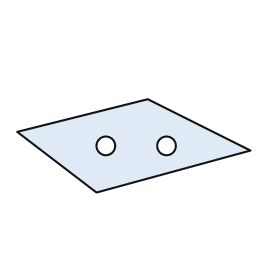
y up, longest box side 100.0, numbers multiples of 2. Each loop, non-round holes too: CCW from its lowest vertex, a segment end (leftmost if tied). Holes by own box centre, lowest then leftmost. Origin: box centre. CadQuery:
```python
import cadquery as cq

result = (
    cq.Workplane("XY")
    .moveTo(-16.0, -20.0)
    .lineTo(50.0, -2.0)
    .lineTo(6.0, 20.0)
    .lineTo(-50.0, 6.0)
    .close()
    .moveTo(-12.0, 0.0)
    .circle(4.0)
    .moveTo(14.0, 0.0)
    .circle(4.0)
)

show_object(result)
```